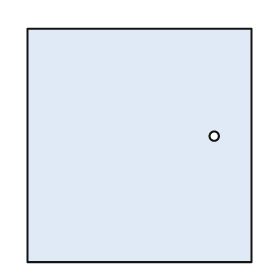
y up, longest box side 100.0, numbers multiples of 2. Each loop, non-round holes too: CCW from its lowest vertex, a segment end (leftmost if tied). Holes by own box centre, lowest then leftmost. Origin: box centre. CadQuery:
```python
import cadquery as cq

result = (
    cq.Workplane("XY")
    .moveTo(-48.0, -50.0)
    .lineTo(48.0, -50.0)
    .lineTo(48.0, 50.0)
    .lineTo(-48.0, 50.0)
    .close()
    .moveTo(32.0, 4.0)
    .circle(2.0)
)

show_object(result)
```